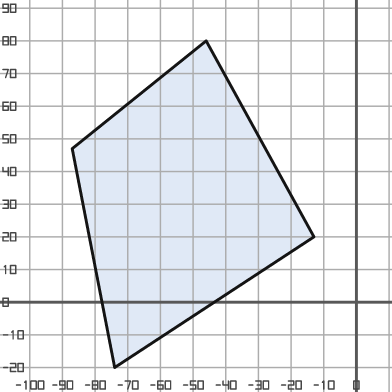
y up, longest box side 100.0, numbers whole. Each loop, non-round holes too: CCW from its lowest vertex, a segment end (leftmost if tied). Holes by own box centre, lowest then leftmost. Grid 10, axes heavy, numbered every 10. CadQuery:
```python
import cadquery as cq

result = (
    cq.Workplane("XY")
    .moveTo(-74.0, -20.0)
    .lineTo(-13.0, 20.0)
    .lineTo(-46.0, 80.0)
    .lineTo(-87.0, 47.0)
    .close()
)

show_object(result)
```